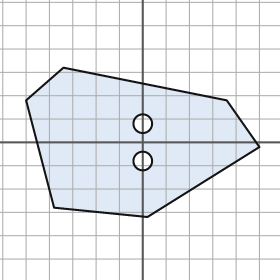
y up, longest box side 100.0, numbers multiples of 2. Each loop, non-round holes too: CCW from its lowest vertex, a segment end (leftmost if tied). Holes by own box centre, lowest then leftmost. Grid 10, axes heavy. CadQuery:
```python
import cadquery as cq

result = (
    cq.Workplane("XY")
    .moveTo(2.0, -32.0)
    .lineTo(50.0, -2.0)
    .lineTo(36.0, 18.0)
    .lineTo(-34.0, 32.0)
    .lineTo(-50.0, 18.0)
    .lineTo(-38.0, -28.0)
    .close()
    .moveTo(0.0, -8.0)
    .circle(4.0)
    .moveTo(0.0, 8.0)
    .circle(4.0)
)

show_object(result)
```